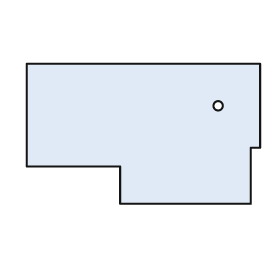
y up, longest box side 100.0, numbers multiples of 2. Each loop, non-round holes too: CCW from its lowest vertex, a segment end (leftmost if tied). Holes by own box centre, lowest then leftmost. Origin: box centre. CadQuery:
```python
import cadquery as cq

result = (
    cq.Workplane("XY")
    .moveTo(-10.0, -30.0)
    .lineTo(46.0, -30.0)
    .lineTo(46.0, -6.0)
    .lineTo(50.0, -6.0)
    .lineTo(50.0, 30.0)
    .lineTo(-50.0, 30.0)
    .lineTo(-50.0, -14.0)
    .lineTo(-10.0, -14.0)
    .close()
    .moveTo(32.0, 12.0)
    .circle(2.0)
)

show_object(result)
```